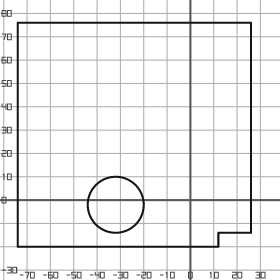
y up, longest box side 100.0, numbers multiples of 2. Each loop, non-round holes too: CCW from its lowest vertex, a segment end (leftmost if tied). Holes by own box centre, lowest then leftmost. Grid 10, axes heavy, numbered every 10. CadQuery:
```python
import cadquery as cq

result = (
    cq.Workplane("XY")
    .moveTo(-74.0, -20.0)
    .lineTo(12.0, -20.0)
    .lineTo(12.0, -14.0)
    .lineTo(26.0, -14.0)
    .lineTo(26.0, 76.0)
    .lineTo(-74.0, 76.0)
    .close()
    .moveTo(-32.0, -2.0)
    .circle(12.0)
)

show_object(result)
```